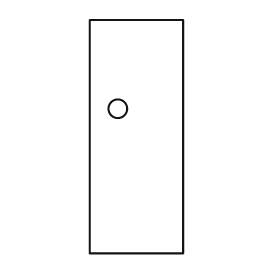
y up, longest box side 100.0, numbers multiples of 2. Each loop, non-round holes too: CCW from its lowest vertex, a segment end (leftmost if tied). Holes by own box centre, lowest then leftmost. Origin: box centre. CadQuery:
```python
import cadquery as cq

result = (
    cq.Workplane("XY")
    .moveTo(-20.0, -50.0)
    .lineTo(20.0, -50.0)
    .lineTo(20.0, 50.0)
    .lineTo(-20.0, 50.0)
    .close()
    .moveTo(-8.0, 12.0)
    .circle(4.0)
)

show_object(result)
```